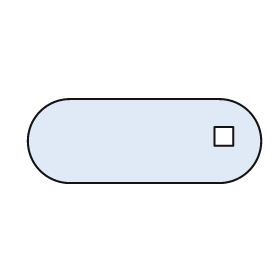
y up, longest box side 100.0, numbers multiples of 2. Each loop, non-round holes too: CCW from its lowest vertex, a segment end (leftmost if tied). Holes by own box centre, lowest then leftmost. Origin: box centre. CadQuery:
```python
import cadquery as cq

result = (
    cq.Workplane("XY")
    .moveTo(-32.0, -18.0)
    .lineTo(32.0, -18.0)
    .threePointArc((50.0, 0.0), (32.0, 18.0))
    .lineTo(-32.0, 18.0)
    .threePointArc((-50.0, 0.0), (-32.0, -18.0))
    .close()
    .moveTo(30.0, -2.0)
    .lineTo(38.0, -2.0)
    .lineTo(38.0, 6.0)
    .lineTo(30.0, 6.0)
    .close()
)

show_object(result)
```